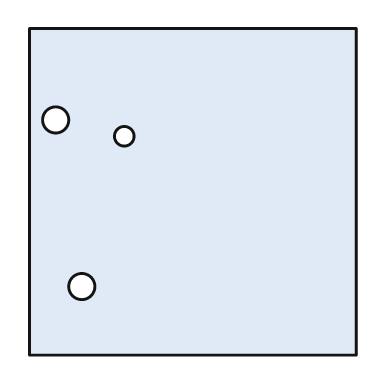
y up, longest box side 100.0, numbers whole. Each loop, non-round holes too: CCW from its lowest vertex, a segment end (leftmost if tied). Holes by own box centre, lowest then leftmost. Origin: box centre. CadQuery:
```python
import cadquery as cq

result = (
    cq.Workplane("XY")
    .moveTo(-50.0, -50.0)
    .lineTo(50.0, -50.0)
    .lineTo(50.0, 50.0)
    .lineTo(-50.0, 50.0)
    .close()
    .moveTo(-34.0, -29.0)
    .circle(4.0)
    .moveTo(-21.0, 17.0)
    .circle(3.0)
    .moveTo(-42.0, 22.0)
    .circle(4.0)
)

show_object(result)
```